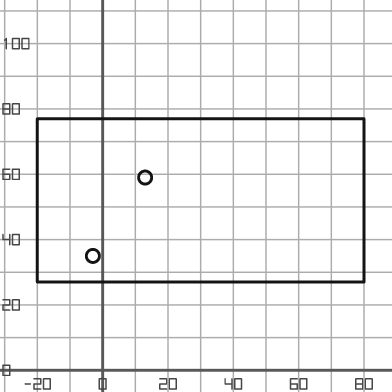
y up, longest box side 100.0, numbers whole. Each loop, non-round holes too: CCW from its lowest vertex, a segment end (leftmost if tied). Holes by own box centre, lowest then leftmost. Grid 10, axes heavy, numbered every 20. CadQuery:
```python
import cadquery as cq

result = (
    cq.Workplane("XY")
    .moveTo(-20.0, 27.0)
    .lineTo(80.0, 27.0)
    .lineTo(80.0, 77.0)
    .lineTo(-20.0, 77.0)
    .close()
    .moveTo(-3.0, 35.0)
    .circle(2.0)
    .moveTo(13.0, 59.0)
    .circle(2.0)
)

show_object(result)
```